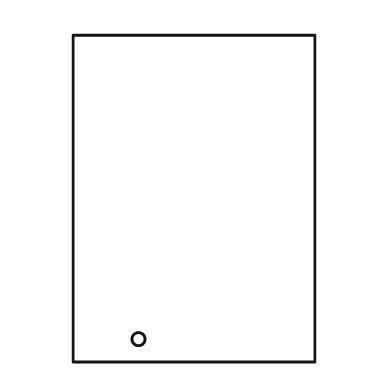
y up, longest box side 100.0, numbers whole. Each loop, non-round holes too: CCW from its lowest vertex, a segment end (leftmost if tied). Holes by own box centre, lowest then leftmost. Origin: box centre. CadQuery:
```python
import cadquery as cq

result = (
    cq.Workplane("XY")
    .moveTo(-37.0, -50.0)
    .lineTo(37.0, -50.0)
    .lineTo(37.0, 50.0)
    .lineTo(-37.0, 50.0)
    .close()
    .moveTo(-17.0, -43.0)
    .circle(2.0)
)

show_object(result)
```